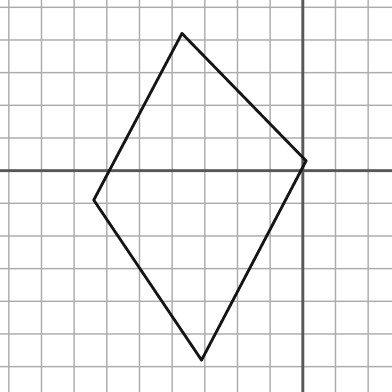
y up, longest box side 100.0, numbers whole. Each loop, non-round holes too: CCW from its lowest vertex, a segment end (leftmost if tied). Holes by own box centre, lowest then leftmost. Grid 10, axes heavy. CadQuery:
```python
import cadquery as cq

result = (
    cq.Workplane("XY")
    .moveTo(-31.0, -58.0)
    .lineTo(1.0, 3.0)
    .lineTo(-37.0, 42.0)
    .lineTo(-64.0, -9.0)
    .close()
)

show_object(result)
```